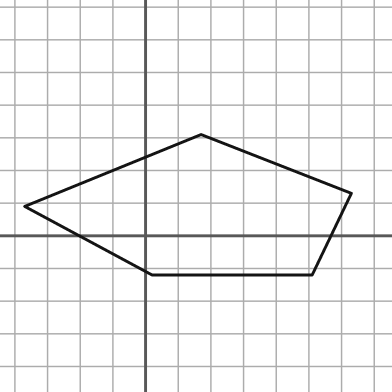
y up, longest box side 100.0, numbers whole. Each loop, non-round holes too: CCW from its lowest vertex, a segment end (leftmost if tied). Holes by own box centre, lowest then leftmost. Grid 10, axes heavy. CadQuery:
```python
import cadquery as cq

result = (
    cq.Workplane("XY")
    .moveTo(2.0, -12.0)
    .lineTo(51.0, -12.0)
    .lineTo(63.0, 13.0)
    .lineTo(17.0, 31.0)
    .lineTo(-37.0, 9.0)
    .close()
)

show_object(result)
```